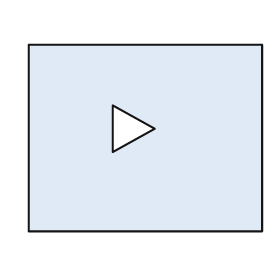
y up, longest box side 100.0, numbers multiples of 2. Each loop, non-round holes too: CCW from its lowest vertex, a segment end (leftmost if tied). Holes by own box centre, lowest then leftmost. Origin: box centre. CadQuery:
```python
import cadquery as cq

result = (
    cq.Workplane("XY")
    .moveTo(-50.0, -40.0)
    .lineTo(50.0, -40.0)
    .lineTo(50.0, 40.0)
    .lineTo(-50.0, 40.0)
    .close()
    .moveTo(-14.0, -6.0)
    .lineTo(4.0, 4.0)
    .lineTo(-14.0, 14.0)
    .close()
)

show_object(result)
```